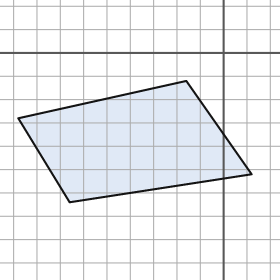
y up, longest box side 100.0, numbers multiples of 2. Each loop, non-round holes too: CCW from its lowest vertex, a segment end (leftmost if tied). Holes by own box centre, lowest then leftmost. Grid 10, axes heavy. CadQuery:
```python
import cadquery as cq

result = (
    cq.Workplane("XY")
    .moveTo(-66.0, -64.0)
    .lineTo(12.0, -52.0)
    .lineTo(-16.0, -12.0)
    .lineTo(-88.0, -28.0)
    .close()
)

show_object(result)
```